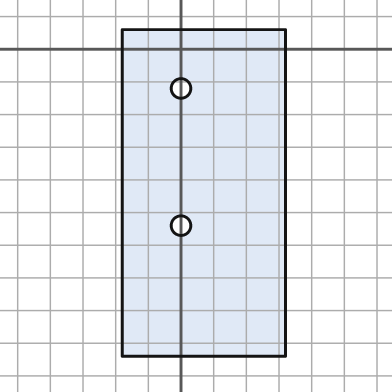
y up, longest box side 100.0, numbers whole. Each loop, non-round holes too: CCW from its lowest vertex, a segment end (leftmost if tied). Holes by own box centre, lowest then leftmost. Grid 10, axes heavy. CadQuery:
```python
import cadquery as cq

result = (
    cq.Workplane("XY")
    .moveTo(-18.0, -94.0)
    .lineTo(32.0, -94.0)
    .lineTo(32.0, 6.0)
    .lineTo(-18.0, 6.0)
    .close()
    .moveTo(0.0, -54.0)
    .circle(3.0)
    .moveTo(0.0, -12.0)
    .circle(3.0)
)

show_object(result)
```